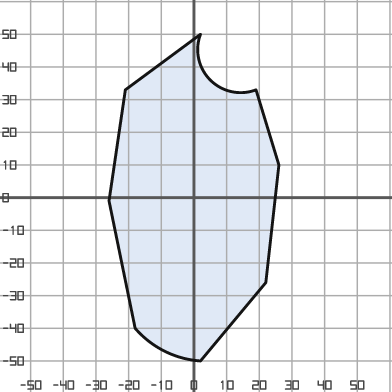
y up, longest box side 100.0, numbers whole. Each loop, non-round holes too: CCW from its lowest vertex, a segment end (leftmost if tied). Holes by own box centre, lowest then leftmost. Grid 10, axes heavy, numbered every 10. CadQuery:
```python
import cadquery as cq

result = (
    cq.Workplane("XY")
    .moveTo(2.0, -50.0)
    .lineTo(22.0, -26.0)
    .lineTo(26.0, 10.0)
    .lineTo(19.0, 33.0)
    .threePointArc((5.0, 36.0), (2.0, 50.0))
    .lineTo(-21.0, 33.0)
    .lineTo(-26.0, -1.0)
    .lineTo(-18.0, -40.0)
    .threePointArc((-9.0, -47.0), (2.0, -50.0))
    .close()
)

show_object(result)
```